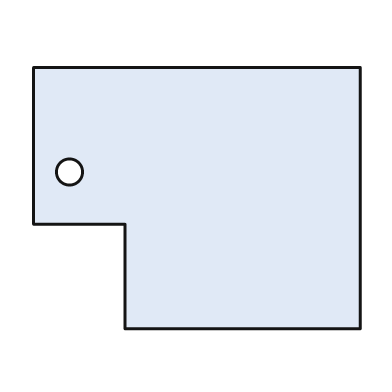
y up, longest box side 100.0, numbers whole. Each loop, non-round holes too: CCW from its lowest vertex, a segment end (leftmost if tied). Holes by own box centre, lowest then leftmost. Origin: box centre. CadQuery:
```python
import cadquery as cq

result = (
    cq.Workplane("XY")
    .moveTo(-22.0, -40.0)
    .lineTo(50.0, -40.0)
    .lineTo(50.0, 40.0)
    .lineTo(-50.0, 40.0)
    .lineTo(-50.0, -8.0)
    .lineTo(-22.0, -8.0)
    .close()
    .moveTo(-39.0, 8.0)
    .circle(4.0)
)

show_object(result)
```